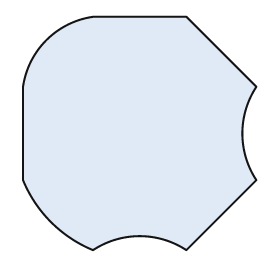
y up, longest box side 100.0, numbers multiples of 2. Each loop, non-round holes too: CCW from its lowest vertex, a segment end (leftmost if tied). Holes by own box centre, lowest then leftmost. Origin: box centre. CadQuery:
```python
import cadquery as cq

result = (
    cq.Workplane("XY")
    .moveTo(-20.0, -50.0)
    .threePointArc((0.0, -44.0), (20.0, -50.0))
    .lineTo(50.0, -20.0)
    .threePointArc((44.0, 0.0), (50.0, 20.0))
    .lineTo(20.0, 50.0)
    .lineTo(-20.0, 50.0)
    .threePointArc((-40.0, 40.0), (-50.0, 20.0))
    .lineTo(-50.0, -20.0)
    .threePointArc((-38.0, -38.0), (-20.0, -50.0))
    .close()
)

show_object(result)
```